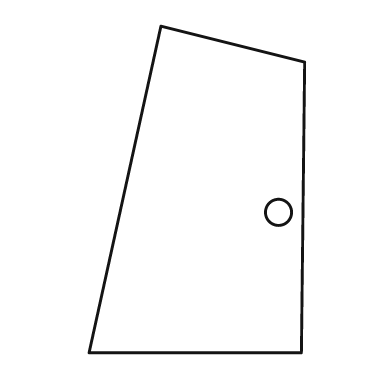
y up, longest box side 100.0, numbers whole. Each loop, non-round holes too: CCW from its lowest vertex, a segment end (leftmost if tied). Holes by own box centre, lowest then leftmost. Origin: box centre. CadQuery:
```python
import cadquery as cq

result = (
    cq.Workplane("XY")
    .moveTo(-33.0, -50.0)
    .lineTo(32.0, -50.0)
    .lineTo(33.0, 39.0)
    .lineTo(-11.0, 50.0)
    .close()
    .moveTo(25.0, -7.0)
    .circle(4.0)
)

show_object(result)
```